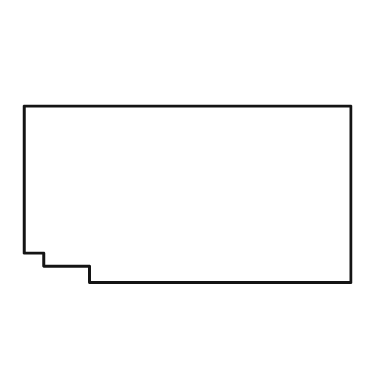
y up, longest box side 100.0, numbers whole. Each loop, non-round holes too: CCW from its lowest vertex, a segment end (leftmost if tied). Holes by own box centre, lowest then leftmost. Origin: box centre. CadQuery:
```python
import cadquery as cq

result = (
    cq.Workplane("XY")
    .moveTo(-30.0, -27.0)
    .lineTo(50.0, -27.0)
    .lineTo(50.0, 27.0)
    .lineTo(-50.0, 27.0)
    .lineTo(-50.0, -18.0)
    .lineTo(-44.0, -18.0)
    .lineTo(-44.0, -22.0)
    .lineTo(-30.0, -22.0)
    .close()
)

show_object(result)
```